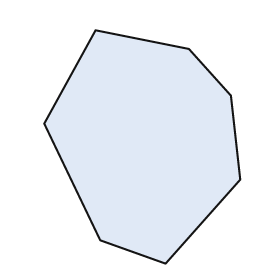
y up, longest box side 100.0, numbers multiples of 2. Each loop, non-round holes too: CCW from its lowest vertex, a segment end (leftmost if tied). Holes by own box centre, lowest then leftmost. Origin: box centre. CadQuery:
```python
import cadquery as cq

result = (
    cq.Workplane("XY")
    .moveTo(10.0, -50.0)
    .lineTo(42.0, -14.0)
    .lineTo(38.0, 22.0)
    .lineTo(20.0, 42.0)
    .lineTo(-20.0, 50.0)
    .lineTo(-42.0, 10.0)
    .lineTo(-18.0, -40.0)
    .close()
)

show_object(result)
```